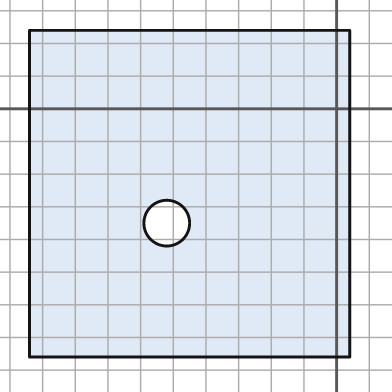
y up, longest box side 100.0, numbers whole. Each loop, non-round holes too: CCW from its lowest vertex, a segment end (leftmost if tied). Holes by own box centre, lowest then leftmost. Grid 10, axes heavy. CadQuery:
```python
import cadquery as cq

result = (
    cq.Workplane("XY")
    .moveTo(-94.0, -76.0)
    .lineTo(4.0, -76.0)
    .lineTo(4.0, 24.0)
    .lineTo(-94.0, 24.0)
    .close()
    .moveTo(-52.0, -35.0)
    .circle(7.0)
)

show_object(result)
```